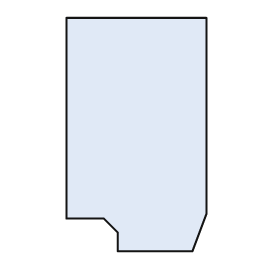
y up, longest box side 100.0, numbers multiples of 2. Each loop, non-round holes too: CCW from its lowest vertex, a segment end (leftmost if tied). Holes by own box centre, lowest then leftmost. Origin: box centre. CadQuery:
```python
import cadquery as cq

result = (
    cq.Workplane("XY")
    .moveTo(-8.0, -50.0)
    .lineTo(24.0, -50.0)
    .lineTo(30.0, -34.0)
    .lineTo(30.0, 50.0)
    .lineTo(-30.0, 50.0)
    .lineTo(-30.0, -36.0)
    .lineTo(-14.0, -36.0)
    .lineTo(-8.0, -42.0)
    .close()
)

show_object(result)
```